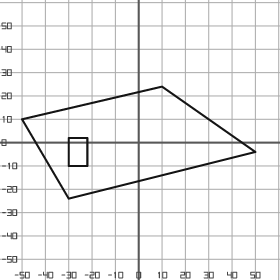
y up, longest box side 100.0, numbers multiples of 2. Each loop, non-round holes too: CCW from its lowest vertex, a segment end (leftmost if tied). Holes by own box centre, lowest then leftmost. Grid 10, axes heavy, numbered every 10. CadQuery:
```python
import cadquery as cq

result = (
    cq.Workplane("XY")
    .moveTo(-30.0, -24.0)
    .lineTo(50.0, -4.0)
    .lineTo(10.0, 24.0)
    .lineTo(-50.0, 10.0)
    .close()
    .moveTo(-30.0, -10.0)
    .lineTo(-22.0, -10.0)
    .lineTo(-22.0, 2.0)
    .lineTo(-30.0, 2.0)
    .close()
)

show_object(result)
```